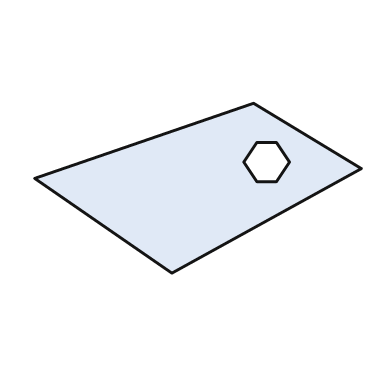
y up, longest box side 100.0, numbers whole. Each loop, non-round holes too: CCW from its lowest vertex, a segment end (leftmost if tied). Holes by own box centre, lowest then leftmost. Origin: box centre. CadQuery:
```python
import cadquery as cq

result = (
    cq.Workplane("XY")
    .moveTo(-8.0, -26.0)
    .lineTo(50.0, 6.0)
    .lineTo(17.0, 26.0)
    .lineTo(-50.0, 3.0)
    .close()
    .moveTo(18.0, 2.0)
    .lineTo(24.0, 2.0)
    .lineTo(28.0, 8.0)
    .lineTo(24.0, 14.0)
    .lineTo(18.0, 14.0)
    .lineTo(14.0, 8.0)
    .close()
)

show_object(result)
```